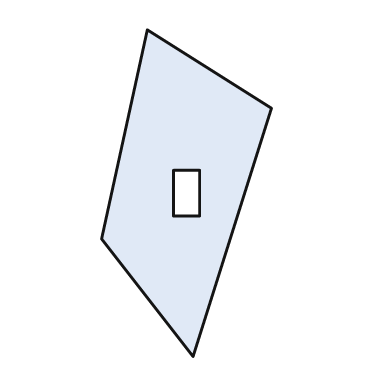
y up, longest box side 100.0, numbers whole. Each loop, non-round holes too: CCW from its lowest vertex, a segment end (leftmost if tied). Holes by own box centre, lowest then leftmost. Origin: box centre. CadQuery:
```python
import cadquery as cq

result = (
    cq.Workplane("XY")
    .moveTo(2.0, -50.0)
    .lineTo(26.0, 26.0)
    .lineTo(-12.0, 50.0)
    .lineTo(-26.0, -14.0)
    .close()
    .moveTo(-4.0, -7.0)
    .lineTo(4.0, -7.0)
    .lineTo(4.0, 7.0)
    .lineTo(-4.0, 7.0)
    .close()
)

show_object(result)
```